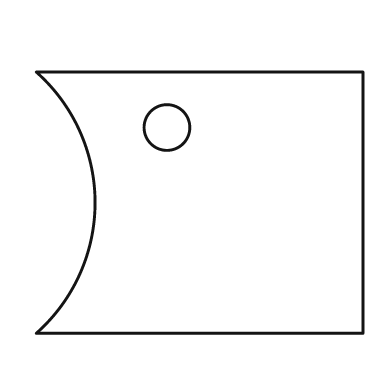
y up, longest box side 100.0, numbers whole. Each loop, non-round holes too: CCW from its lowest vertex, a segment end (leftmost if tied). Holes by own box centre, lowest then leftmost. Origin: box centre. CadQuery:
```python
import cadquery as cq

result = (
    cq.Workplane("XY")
    .moveTo(-50.0, -40.0)
    .lineTo(50.0, -40.0)
    .lineTo(50.0, 40.0)
    .lineTo(-50.0, 40.0)
    .threePointArc((-32.0, 0.0), (-50.0, -40.0))
    .close()
    .moveTo(-10.0, 23.0)
    .circle(7.0)
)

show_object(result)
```